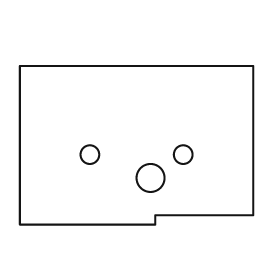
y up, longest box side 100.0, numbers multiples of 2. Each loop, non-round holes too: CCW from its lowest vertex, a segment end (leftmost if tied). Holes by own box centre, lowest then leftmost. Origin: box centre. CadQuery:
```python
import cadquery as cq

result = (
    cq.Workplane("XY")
    .moveTo(-50.0, -34.0)
    .lineTo(8.0, -34.0)
    .lineTo(8.0, -30.0)
    .lineTo(50.0, -30.0)
    .lineTo(50.0, 34.0)
    .lineTo(-50.0, 34.0)
    .close()
    .moveTo(6.0, -14.0)
    .circle(6.0)
    .moveTo(-20.0, -4.0)
    .circle(4.0)
    .moveTo(20.0, -4.0)
    .circle(4.0)
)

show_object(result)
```